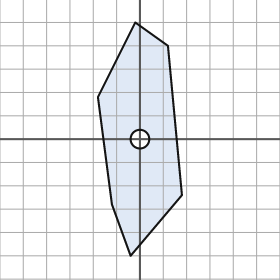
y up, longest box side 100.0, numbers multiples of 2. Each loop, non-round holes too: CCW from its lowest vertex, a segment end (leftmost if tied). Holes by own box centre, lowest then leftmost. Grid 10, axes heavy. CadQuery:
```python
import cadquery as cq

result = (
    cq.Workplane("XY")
    .moveTo(-4.0, -50.0)
    .lineTo(18.0, -24.0)
    .lineTo(12.0, 40.0)
    .lineTo(-2.0, 50.0)
    .lineTo(-18.0, 18.0)
    .lineTo(-12.0, -28.0)
    .close()
    .moveTo(0.0, 0.0)
    .circle(4.0)
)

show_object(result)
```